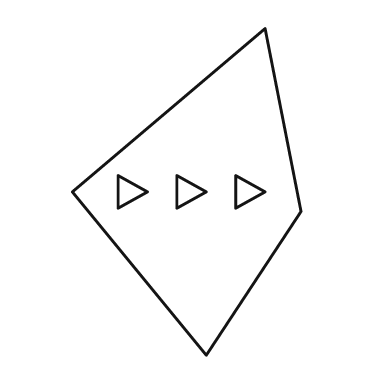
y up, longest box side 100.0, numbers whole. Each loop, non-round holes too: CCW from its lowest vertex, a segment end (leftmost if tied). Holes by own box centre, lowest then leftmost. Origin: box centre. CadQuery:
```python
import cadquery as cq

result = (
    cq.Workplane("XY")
    .moveTo(6.0, -50.0)
    .lineTo(35.0, -6.0)
    .lineTo(24.0, 50.0)
    .lineTo(-35.0, 0.0)
    .close()
    .moveTo(-21.0, -5.0)
    .lineTo(-12.0, 0.0)
    .lineTo(-21.0, 5.0)
    .close()
    .moveTo(-3.0, -5.0)
    .lineTo(6.0, 0.0)
    .lineTo(-3.0, 5.0)
    .close()
    .moveTo(15.0, -5.0)
    .lineTo(24.0, 0.0)
    .lineTo(15.0, 5.0)
    .close()
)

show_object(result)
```